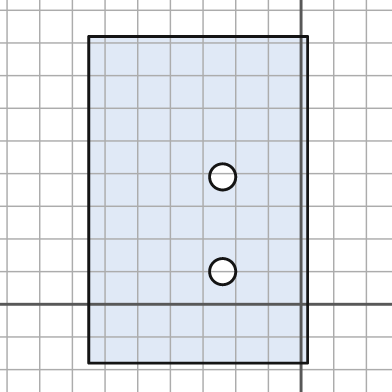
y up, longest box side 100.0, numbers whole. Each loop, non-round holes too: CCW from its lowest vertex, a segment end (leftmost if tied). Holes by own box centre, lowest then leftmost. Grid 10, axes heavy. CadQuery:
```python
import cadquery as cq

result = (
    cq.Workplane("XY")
    .moveTo(-65.0, -18.0)
    .lineTo(2.0, -18.0)
    .lineTo(2.0, 82.0)
    .lineTo(-65.0, 82.0)
    .close()
    .moveTo(-24.0, 10.0)
    .circle(4.0)
    .moveTo(-24.0, 39.0)
    .circle(4.0)
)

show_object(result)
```